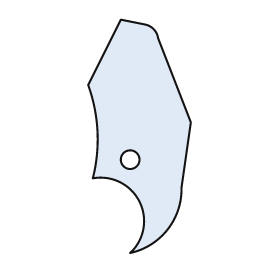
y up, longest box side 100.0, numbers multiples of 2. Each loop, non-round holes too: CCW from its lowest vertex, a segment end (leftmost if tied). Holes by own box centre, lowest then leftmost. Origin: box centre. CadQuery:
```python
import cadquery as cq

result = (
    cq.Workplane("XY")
    .moveTo(-4.0, -50.0)
    .threePointArc((12.0, -40.0), (18.0, -22.0))
    .lineTo(22.0, 6.0)
    .lineTo(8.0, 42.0)
    .threePointArc((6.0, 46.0), (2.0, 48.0))
    .lineTo(-8.0, 50.0)
    .lineTo(-22.0, 22.0)
    .threePointArc((-18.0, 2.0), (-20.0, -18.0))
    .threePointArc((0.0, -28.0), (-4.0, -50.0))
    .close()
    .moveTo(-4.0, -10.0)
    .circle(4.0)
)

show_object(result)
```